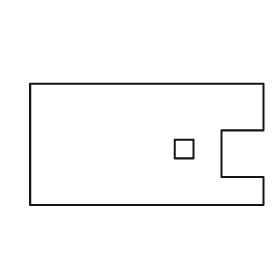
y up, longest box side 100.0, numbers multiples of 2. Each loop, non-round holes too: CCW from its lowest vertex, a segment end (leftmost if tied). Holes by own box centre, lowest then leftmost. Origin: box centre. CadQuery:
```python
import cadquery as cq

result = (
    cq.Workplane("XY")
    .moveTo(-50.0, -26.0)
    .lineTo(50.0, -26.0)
    .lineTo(50.0, -14.0)
    .lineTo(32.0, -14.0)
    .lineTo(32.0, 6.0)
    .lineTo(50.0, 6.0)
    .lineTo(50.0, 26.0)
    .lineTo(-50.0, 26.0)
    .close()
    .moveTo(12.0, -6.0)
    .lineTo(20.0, -6.0)
    .lineTo(20.0, 2.0)
    .lineTo(12.0, 2.0)
    .close()
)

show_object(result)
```